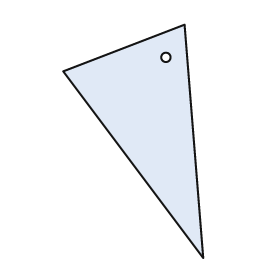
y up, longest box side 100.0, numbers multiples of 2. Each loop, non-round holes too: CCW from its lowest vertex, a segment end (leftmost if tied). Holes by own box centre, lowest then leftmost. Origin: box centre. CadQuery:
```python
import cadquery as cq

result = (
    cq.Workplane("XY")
    .moveTo(30.0, -50.0)
    .lineTo(22.0, 50.0)
    .lineTo(-30.0, 30.0)
    .close()
    .moveTo(14.0, 36.0)
    .circle(2.0)
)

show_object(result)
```